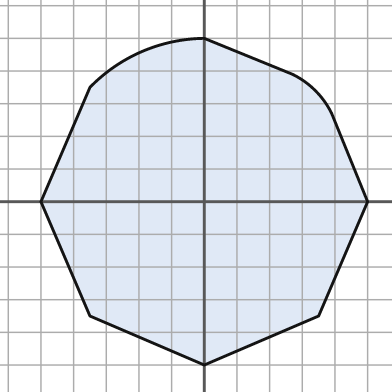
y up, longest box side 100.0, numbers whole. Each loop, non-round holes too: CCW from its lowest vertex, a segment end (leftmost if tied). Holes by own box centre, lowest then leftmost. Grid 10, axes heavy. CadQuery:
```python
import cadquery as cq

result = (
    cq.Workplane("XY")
    .moveTo(0.0, -50.0)
    .lineTo(35.0, -35.0)
    .lineTo(50.0, 0.0)
    .lineTo(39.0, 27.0)
    .threePointArc((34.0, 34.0), (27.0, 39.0))
    .lineTo(0.0, 50.0)
    .threePointArc((-19.0, 46.0), (-35.0, 35.0))
    .lineTo(-50.0, 0.0)
    .lineTo(-35.0, -35.0)
    .close()
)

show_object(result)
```